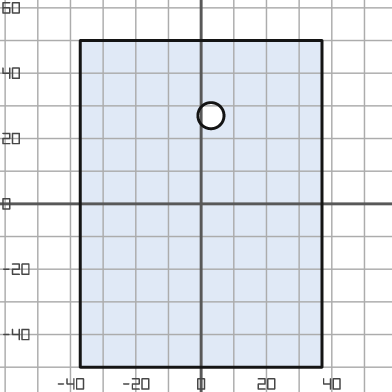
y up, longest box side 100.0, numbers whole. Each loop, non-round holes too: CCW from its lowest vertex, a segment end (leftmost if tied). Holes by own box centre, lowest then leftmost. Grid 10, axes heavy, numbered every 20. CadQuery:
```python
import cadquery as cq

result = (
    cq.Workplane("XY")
    .moveTo(-37.0, -50.0)
    .lineTo(37.0, -50.0)
    .lineTo(37.0, 50.0)
    .lineTo(-37.0, 50.0)
    .close()
    .moveTo(3.0, 27.0)
    .circle(4.0)
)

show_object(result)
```